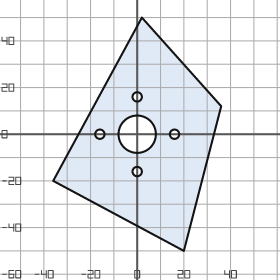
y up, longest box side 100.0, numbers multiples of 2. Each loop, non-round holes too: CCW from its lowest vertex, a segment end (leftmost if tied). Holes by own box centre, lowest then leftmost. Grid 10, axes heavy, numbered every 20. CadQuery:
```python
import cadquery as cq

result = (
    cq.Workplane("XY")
    .moveTo(20.0, -50.0)
    .lineTo(36.0, 12.0)
    .lineTo(2.0, 50.0)
    .lineTo(-36.0, -20.0)
    .close()
    .moveTo(0.0, -16.0)
    .circle(2.0)
    .moveTo(-16.0, 0.0)
    .circle(2.0)
    .moveTo(0.0, 0.0)
    .circle(8.0)
    .moveTo(16.0, 0.0)
    .circle(2.0)
    .moveTo(0.0, 16.0)
    .circle(2.0)
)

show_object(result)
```